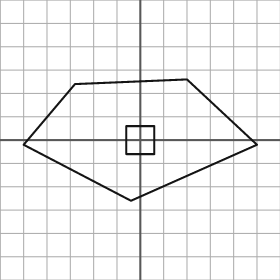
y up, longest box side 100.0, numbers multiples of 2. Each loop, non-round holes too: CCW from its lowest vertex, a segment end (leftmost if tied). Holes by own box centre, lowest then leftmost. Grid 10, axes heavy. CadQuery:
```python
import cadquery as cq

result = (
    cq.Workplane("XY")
    .moveTo(-4.0, -26.0)
    .lineTo(50.0, -2.0)
    .lineTo(20.0, 26.0)
    .lineTo(-28.0, 24.0)
    .lineTo(-50.0, -2.0)
    .close()
    .moveTo(-6.0, -6.0)
    .lineTo(6.0, -6.0)
    .lineTo(6.0, 6.0)
    .lineTo(-6.0, 6.0)
    .close()
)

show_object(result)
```